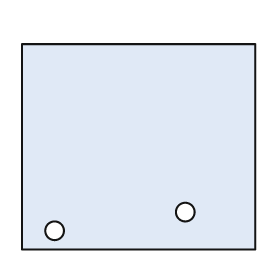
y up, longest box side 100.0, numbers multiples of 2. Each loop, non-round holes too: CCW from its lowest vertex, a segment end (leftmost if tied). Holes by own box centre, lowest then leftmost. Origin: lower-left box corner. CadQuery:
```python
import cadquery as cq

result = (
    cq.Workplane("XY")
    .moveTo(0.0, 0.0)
    .lineTo(100.0, 0.0)
    .lineTo(100.0, 88.0)
    .lineTo(0.0, 88.0)
    .close()
    .moveTo(14.0, 8.0)
    .circle(4.0)
    .moveTo(70.0, 16.0)
    .circle(4.0)
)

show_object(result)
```